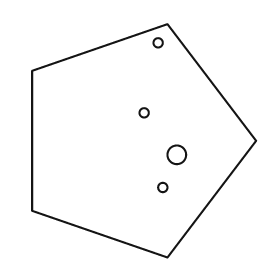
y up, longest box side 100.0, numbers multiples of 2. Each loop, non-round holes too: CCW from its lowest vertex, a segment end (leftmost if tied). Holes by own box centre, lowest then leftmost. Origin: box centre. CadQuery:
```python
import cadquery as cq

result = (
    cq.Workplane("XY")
    .moveTo(10.0, -50.0)
    .lineTo(48.0, 0.0)
    .lineTo(10.0, 50.0)
    .lineTo(-48.0, 30.0)
    .lineTo(-48.0, -30.0)
    .close()
    .moveTo(8.0, -20.0)
    .circle(2.0)
    .moveTo(14.0, -6.0)
    .circle(4.0)
    .moveTo(0.0, 12.0)
    .circle(2.0)
    .moveTo(6.0, 42.0)
    .circle(2.0)
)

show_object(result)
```